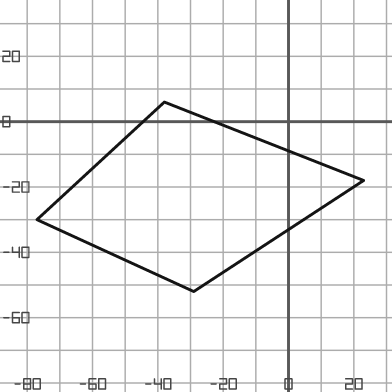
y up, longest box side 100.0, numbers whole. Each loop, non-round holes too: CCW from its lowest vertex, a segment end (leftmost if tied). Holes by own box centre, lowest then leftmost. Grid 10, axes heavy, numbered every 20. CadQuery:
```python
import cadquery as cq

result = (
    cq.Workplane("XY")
    .moveTo(-29.0, -52.0)
    .lineTo(23.0, -18.0)
    .lineTo(-38.0, 6.0)
    .lineTo(-77.0, -30.0)
    .close()
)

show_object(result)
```